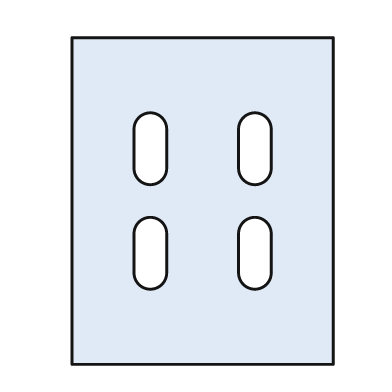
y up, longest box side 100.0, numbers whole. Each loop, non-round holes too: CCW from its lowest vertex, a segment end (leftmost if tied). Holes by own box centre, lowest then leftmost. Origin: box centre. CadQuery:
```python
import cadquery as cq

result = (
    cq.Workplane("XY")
    .moveTo(-40.0, -50.0)
    .lineTo(40.0, -50.0)
    .lineTo(40.0, 50.0)
    .lineTo(-40.0, 50.0)
    .close()
    .moveTo(-21.0, -22.0)
    .threePointArc((-16.0, -27.0), (-11.0, -22.0))
    .lineTo(-11.0, -10.0)
    .threePointArc((-16.0, -5.0), (-21.0, -10.0))
    .close()
    .moveTo(11.0, -22.0)
    .threePointArc((16.0, -27.0), (21.0, -22.0))
    .lineTo(21.0, -10.0)
    .threePointArc((16.0, -5.0), (11.0, -10.0))
    .close()
    .moveTo(-21.0, 10.0)
    .threePointArc((-16.0, 5.0), (-11.0, 10.0))
    .lineTo(-11.0, 22.0)
    .threePointArc((-16.0, 27.0), (-21.0, 22.0))
    .close()
    .moveTo(11.0, 10.0)
    .threePointArc((16.0, 5.0), (21.0, 10.0))
    .lineTo(21.0, 22.0)
    .threePointArc((16.0, 27.0), (11.0, 22.0))
    .close()
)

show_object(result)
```